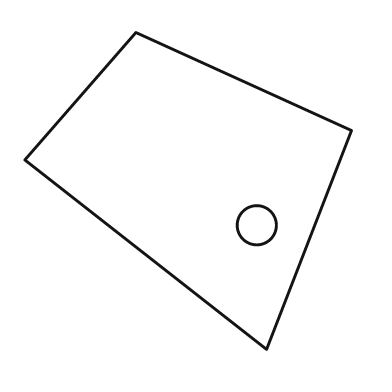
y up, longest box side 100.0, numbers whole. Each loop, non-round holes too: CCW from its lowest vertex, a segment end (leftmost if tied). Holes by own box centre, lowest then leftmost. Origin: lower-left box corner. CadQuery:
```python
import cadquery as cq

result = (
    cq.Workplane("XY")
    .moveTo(74.0, 0.0)
    .lineTo(100.0, 67.0)
    .lineTo(34.0, 97.0)
    .lineTo(0.0, 58.0)
    .close()
    .moveTo(71.0, 38.0)
    .circle(6.0)
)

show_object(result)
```